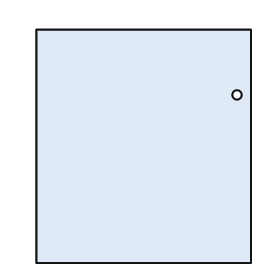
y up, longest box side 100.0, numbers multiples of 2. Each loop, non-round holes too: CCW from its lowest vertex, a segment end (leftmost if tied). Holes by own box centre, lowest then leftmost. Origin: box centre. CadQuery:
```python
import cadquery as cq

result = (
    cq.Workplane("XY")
    .moveTo(-46.0, -50.0)
    .lineTo(46.0, -50.0)
    .lineTo(46.0, 50.0)
    .lineTo(-46.0, 50.0)
    .close()
    .moveTo(40.0, 22.0)
    .circle(2.0)
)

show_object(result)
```